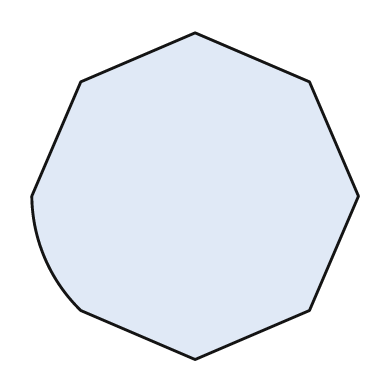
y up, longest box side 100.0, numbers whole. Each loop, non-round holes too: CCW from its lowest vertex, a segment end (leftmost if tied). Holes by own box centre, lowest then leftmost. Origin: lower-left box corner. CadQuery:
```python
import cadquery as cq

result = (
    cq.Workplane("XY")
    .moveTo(50.0, 0.0)
    .lineTo(85.0, 15.0)
    .lineTo(100.0, 50.0)
    .lineTo(85.0, 85.0)
    .lineTo(50.0, 100.0)
    .lineTo(15.0, 85.0)
    .lineTo(0.0, 50.0)
    .threePointArc((4.0, 31.0), (15.0, 15.0))
    .close()
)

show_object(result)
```